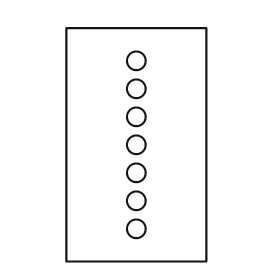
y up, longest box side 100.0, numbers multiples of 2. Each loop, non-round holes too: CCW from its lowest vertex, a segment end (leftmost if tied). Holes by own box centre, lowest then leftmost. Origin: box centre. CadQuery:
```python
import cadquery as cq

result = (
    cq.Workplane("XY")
    .moveTo(-30.0, -50.0)
    .lineTo(30.0, -50.0)
    .lineTo(30.0, 50.0)
    .lineTo(-30.0, 50.0)
    .close()
    .moveTo(0.0, -36.0)
    .circle(4.0)
    .moveTo(0.0, -24.0)
    .circle(4.0)
    .moveTo(0.0, -12.0)
    .circle(4.0)
    .moveTo(0.0, 0.0)
    .circle(4.0)
    .moveTo(0.0, 12.0)
    .circle(4.0)
    .moveTo(0.0, 24.0)
    .circle(4.0)
    .moveTo(0.0, 36.0)
    .circle(4.0)
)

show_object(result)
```